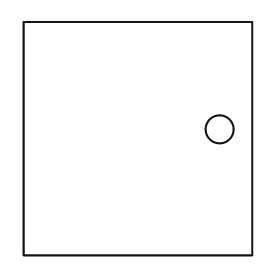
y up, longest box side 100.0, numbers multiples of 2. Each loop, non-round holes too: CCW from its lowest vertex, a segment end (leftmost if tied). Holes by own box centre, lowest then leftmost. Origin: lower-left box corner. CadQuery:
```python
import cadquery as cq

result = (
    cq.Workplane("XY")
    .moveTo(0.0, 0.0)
    .lineTo(98.0, 0.0)
    .lineTo(98.0, 100.0)
    .lineTo(0.0, 100.0)
    .close()
    .moveTo(84.0, 54.0)
    .circle(6.0)
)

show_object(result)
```